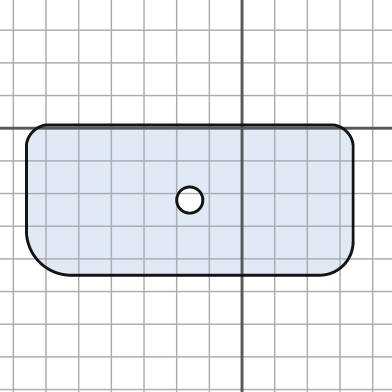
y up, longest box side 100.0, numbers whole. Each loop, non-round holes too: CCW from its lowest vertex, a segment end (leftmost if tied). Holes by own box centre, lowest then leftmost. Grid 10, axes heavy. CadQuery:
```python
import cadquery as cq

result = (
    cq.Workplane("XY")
    .moveTo(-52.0, -45.0)
    .lineTo(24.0, -45.0)
    .threePointArc((31.0, -42.0), (34.0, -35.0))
    .lineTo(34.0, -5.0)
    .threePointArc((32.0, -1.0), (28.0, 1.0))
    .lineTo(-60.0, 1.0)
    .threePointArc((-64.0, -1.0), (-66.0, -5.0))
    .lineTo(-66.0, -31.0)
    .threePointArc((-62.0, -41.0), (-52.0, -45.0))
    .close()
    .moveTo(-16.0, -22.0)
    .circle(4.0)
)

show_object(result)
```